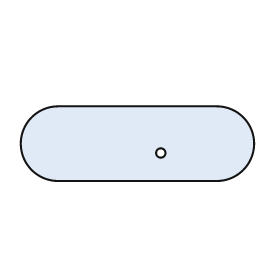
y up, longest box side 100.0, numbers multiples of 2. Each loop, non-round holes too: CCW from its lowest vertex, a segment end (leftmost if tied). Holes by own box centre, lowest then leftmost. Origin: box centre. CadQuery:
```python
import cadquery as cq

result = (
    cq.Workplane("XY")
    .moveTo(-34.0, -16.0)
    .lineTo(34.0, -16.0)
    .threePointArc((50.0, 0.0), (34.0, 16.0))
    .lineTo(-34.0, 16.0)
    .threePointArc((-50.0, 0.0), (-34.0, -16.0))
    .close()
    .moveTo(10.0, -4.0)
    .circle(2.0)
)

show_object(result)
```